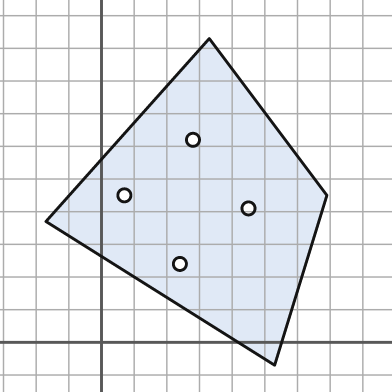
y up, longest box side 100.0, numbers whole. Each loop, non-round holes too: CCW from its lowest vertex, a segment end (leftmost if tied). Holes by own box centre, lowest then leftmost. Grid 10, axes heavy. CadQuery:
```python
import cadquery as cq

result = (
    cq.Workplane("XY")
    .moveTo(53.0, -7.0)
    .lineTo(69.0, 45.0)
    .lineTo(33.0, 93.0)
    .lineTo(-17.0, 37.0)
    .close()
    .moveTo(24.0, 24.0)
    .circle(2.0)
    .moveTo(45.0, 41.0)
    .circle(2.0)
    .moveTo(7.0, 45.0)
    .circle(2.0)
    .moveTo(28.0, 62.0)
    .circle(2.0)
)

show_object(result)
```